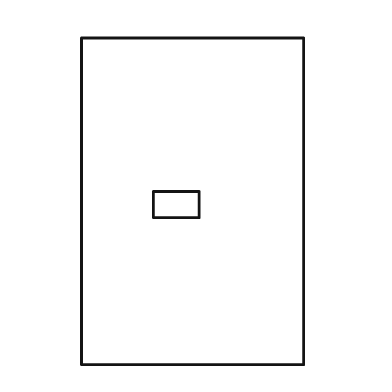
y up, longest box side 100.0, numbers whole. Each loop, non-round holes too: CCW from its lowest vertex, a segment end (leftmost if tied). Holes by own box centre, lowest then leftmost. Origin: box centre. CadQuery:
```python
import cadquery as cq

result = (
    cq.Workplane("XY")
    .moveTo(-34.0, -50.0)
    .lineTo(34.0, -50.0)
    .lineTo(34.0, 50.0)
    .lineTo(-34.0, 50.0)
    .close()
    .moveTo(-12.0, -5.0)
    .lineTo(2.0, -5.0)
    .lineTo(2.0, 3.0)
    .lineTo(-12.0, 3.0)
    .close()
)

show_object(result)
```